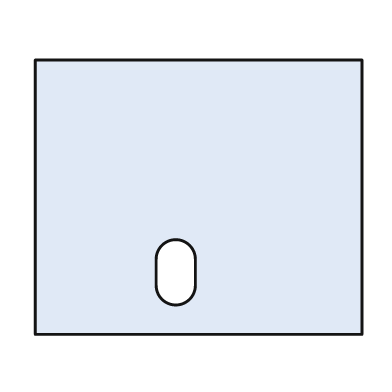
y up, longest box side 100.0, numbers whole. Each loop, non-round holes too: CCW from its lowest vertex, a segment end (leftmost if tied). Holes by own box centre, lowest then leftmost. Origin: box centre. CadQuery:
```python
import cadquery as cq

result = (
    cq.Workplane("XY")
    .moveTo(-50.0, -42.0)
    .lineTo(50.0, -42.0)
    .lineTo(50.0, 42.0)
    .lineTo(-50.0, 42.0)
    .close()
    .moveTo(-13.0, -27.0)
    .threePointArc((-7.0, -33.0), (-1.0, -27.0))
    .lineTo(-1.0, -19.0)
    .threePointArc((-7.0, -13.0), (-13.0, -19.0))
    .close()
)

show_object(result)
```